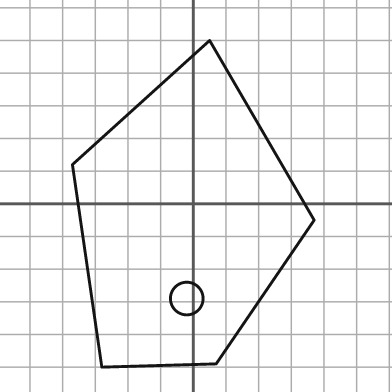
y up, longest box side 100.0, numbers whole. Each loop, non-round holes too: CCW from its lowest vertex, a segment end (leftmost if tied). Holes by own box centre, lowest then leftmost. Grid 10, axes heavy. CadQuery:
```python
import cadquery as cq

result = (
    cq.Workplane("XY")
    .moveTo(-28.0, -50.0)
    .lineTo(7.0, -49.0)
    .lineTo(37.0, -5.0)
    .lineTo(5.0, 50.0)
    .lineTo(-37.0, 12.0)
    .close()
    .moveTo(-2.0, -29.0)
    .circle(5.0)
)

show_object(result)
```